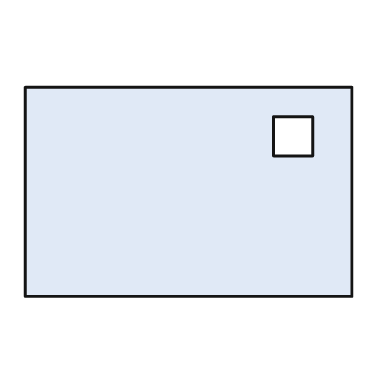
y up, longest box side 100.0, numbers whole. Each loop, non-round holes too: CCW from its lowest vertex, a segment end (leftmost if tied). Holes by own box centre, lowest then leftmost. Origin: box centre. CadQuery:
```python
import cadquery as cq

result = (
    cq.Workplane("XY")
    .moveTo(-50.0, -32.0)
    .lineTo(50.0, -32.0)
    .lineTo(50.0, 32.0)
    .lineTo(-50.0, 32.0)
    .close()
    .moveTo(26.0, 11.0)
    .lineTo(38.0, 11.0)
    .lineTo(38.0, 23.0)
    .lineTo(26.0, 23.0)
    .close()
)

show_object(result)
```